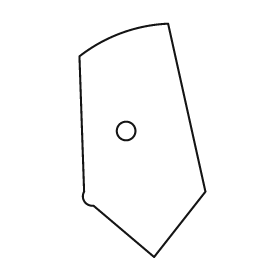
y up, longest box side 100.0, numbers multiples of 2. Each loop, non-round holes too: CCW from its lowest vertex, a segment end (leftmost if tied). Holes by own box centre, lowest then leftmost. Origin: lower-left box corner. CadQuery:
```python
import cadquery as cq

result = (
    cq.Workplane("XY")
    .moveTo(32.0, 0.0)
    .lineTo(54.0, 28.0)
    .lineTo(38.0, 100.0)
    .threePointArc((18.0, 96.0), (0.0, 86.0))
    .lineTo(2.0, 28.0)
    .threePointArc((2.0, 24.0), (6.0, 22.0))
    .close()
    .moveTo(20.0, 54.0)
    .circle(4.0)
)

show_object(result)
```